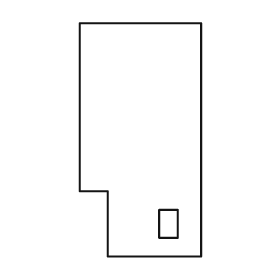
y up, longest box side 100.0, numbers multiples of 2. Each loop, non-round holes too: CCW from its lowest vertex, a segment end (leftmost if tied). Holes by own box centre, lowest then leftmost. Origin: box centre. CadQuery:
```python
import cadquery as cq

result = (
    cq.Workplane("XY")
    .moveTo(-14.0, -50.0)
    .lineTo(26.0, -50.0)
    .lineTo(26.0, 50.0)
    .lineTo(-26.0, 50.0)
    .lineTo(-26.0, -22.0)
    .lineTo(-14.0, -22.0)
    .close()
    .moveTo(8.0, -42.0)
    .lineTo(16.0, -42.0)
    .lineTo(16.0, -30.0)
    .lineTo(8.0, -30.0)
    .close()
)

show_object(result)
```